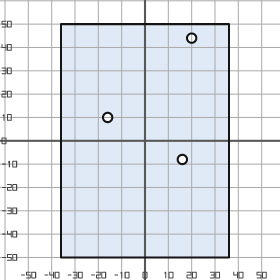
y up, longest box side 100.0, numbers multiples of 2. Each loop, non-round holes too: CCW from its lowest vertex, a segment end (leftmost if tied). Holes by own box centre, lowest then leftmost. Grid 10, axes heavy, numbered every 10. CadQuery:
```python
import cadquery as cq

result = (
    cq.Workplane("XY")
    .moveTo(-36.0, -50.0)
    .lineTo(36.0, -50.0)
    .lineTo(36.0, 50.0)
    .lineTo(-36.0, 50.0)
    .close()
    .moveTo(16.0, -8.0)
    .circle(2.0)
    .moveTo(-16.0, 10.0)
    .circle(2.0)
    .moveTo(20.0, 44.0)
    .circle(2.0)
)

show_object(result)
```